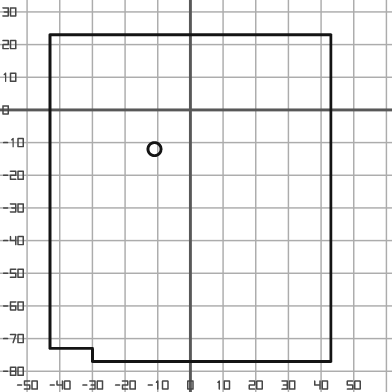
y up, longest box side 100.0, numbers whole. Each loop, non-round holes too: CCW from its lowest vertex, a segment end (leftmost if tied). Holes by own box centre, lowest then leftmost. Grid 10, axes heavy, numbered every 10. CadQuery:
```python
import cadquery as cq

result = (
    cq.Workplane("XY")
    .moveTo(-30.0, -77.0)
    .lineTo(43.0, -77.0)
    .lineTo(43.0, 23.0)
    .lineTo(-43.0, 23.0)
    .lineTo(-43.0, -73.0)
    .lineTo(-30.0, -73.0)
    .close()
    .moveTo(-11.0, -12.0)
    .circle(2.0)
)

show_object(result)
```